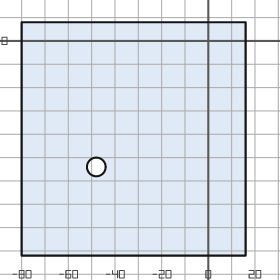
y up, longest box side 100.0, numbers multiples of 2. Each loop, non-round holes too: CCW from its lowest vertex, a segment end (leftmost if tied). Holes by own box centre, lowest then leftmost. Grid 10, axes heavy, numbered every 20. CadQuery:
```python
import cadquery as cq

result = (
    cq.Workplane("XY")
    .moveTo(-80.0, -92.0)
    .lineTo(16.0, -92.0)
    .lineTo(16.0, 8.0)
    .lineTo(-80.0, 8.0)
    .close()
    .moveTo(-48.0, -54.0)
    .circle(4.0)
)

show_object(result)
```